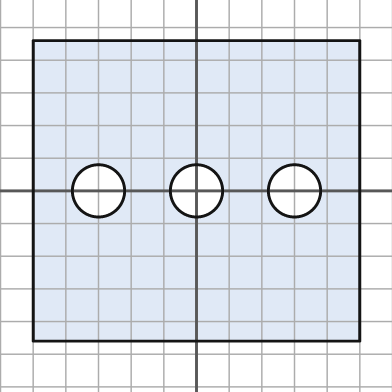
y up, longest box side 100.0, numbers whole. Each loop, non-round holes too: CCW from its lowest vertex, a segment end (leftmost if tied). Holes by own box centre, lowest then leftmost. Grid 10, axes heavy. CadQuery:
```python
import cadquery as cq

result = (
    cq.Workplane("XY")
    .moveTo(-50.0, -46.0)
    .lineTo(50.0, -46.0)
    .lineTo(50.0, 46.0)
    .lineTo(-50.0, 46.0)
    .close()
    .moveTo(-30.0, 0.0)
    .circle(8.0)
    .moveTo(0.0, 0.0)
    .circle(8.0)
    .moveTo(30.0, 0.0)
    .circle(8.0)
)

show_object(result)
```